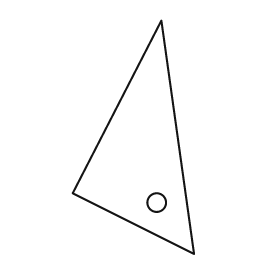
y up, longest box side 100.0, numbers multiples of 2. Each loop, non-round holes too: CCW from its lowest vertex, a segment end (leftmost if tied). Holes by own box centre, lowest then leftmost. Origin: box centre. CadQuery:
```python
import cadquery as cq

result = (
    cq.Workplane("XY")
    .moveTo(26.0, -50.0)
    .lineTo(12.0, 50.0)
    .lineTo(-26.0, -24.0)
    .close()
    .moveTo(10.0, -28.0)
    .circle(4.0)
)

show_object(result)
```